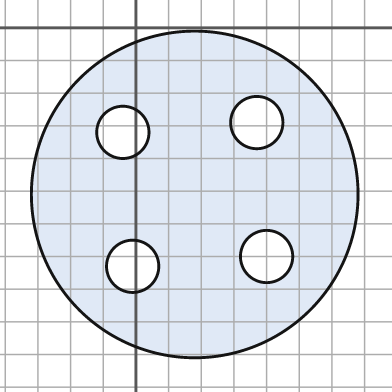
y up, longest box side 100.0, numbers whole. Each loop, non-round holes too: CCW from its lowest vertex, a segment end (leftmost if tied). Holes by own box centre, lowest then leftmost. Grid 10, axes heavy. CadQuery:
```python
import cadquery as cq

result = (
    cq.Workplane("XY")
    .moveTo(18.0, -51.0)
    .circle(50.0)
    .moveTo(-1.0, -73.0)
    .circle(8.0)
    .moveTo(40.0, -70.0)
    .circle(8.0)
    .moveTo(-4.0, -32.0)
    .circle(8.0)
    .moveTo(37.0, -29.0)
    .circle(8.0)
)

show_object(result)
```